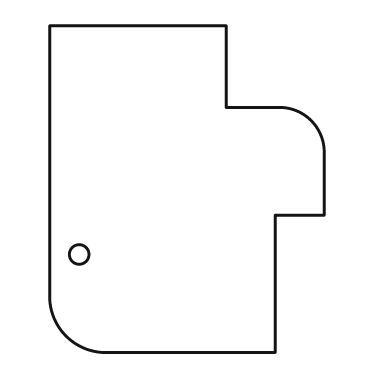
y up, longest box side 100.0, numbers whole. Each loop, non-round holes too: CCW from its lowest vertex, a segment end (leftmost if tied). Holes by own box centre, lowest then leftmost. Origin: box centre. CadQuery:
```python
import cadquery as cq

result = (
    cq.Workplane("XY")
    .moveTo(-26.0, -50.0)
    .lineTo(27.0, -50.0)
    .lineTo(27.0, -8.0)
    .lineTo(42.0, -8.0)
    .lineTo(42.0, 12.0)
    .threePointArc((38.0, 21.0), (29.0, 25.0))
    .lineTo(12.0, 25.0)
    .lineTo(12.0, 50.0)
    .lineTo(-42.0, 50.0)
    .lineTo(-42.0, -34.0)
    .threePointArc((-37.0, -45.0), (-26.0, -50.0))
    .close()
    .moveTo(-33.0, -20.0)
    .circle(3.0)
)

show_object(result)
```